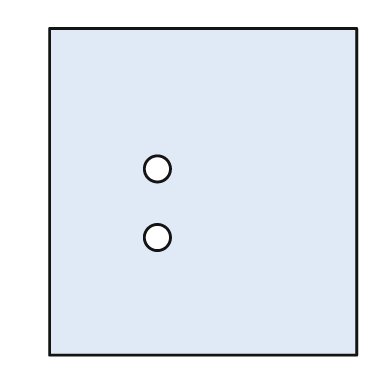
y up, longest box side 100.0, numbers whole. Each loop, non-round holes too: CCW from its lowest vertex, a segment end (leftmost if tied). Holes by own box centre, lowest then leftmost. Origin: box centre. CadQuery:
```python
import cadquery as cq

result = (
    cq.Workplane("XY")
    .moveTo(-47.0, -50.0)
    .lineTo(47.0, -50.0)
    .lineTo(47.0, 50.0)
    .lineTo(-47.0, 50.0)
    .close()
    .moveTo(-14.0, -14.0)
    .circle(4.0)
    .moveTo(-14.0, 7.0)
    .circle(4.0)
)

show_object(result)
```